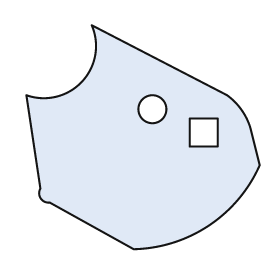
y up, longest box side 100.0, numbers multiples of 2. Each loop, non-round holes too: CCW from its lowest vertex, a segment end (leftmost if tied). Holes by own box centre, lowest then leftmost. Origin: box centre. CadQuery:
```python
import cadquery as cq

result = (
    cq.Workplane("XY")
    .moveTo(-4.0, -48.0)
    .threePointArc((28.0, -38.0), (50.0, -12.0))
    .lineTo(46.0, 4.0)
    .threePointArc((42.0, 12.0), (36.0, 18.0))
    .lineTo(-22.0, 48.0)
    .threePointArc((-26.0, 24.0), (-50.0, 18.0))
    .lineTo(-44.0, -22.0)
    .threePointArc((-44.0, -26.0), (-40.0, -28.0))
    .close()
    .moveTo(20.0, -4.0)
    .lineTo(32.0, -4.0)
    .lineTo(32.0, 8.0)
    .lineTo(20.0, 8.0)
    .close()
    .moveTo(4.0, 12.0)
    .circle(6.0)
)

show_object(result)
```